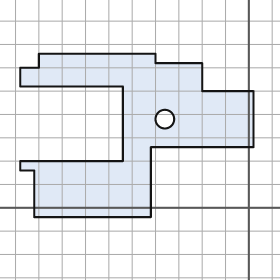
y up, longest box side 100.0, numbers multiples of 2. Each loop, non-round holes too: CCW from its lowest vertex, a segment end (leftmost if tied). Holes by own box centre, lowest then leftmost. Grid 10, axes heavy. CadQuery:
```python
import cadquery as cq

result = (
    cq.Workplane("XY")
    .moveTo(-92.0, -4.0)
    .lineTo(-42.0, -4.0)
    .lineTo(-42.0, 26.0)
    .lineTo(2.0, 26.0)
    .lineTo(2.0, 50.0)
    .lineTo(-20.0, 50.0)
    .lineTo(-20.0, 62.0)
    .lineTo(-40.0, 62.0)
    .lineTo(-40.0, 66.0)
    .lineTo(-90.0, 66.0)
    .lineTo(-90.0, 60.0)
    .lineTo(-98.0, 60.0)
    .lineTo(-98.0, 52.0)
    .lineTo(-54.0, 52.0)
    .lineTo(-54.0, 20.0)
    .lineTo(-98.0, 20.0)
    .lineTo(-98.0, 16.0)
    .lineTo(-92.0, 16.0)
    .close()
    .moveTo(-36.0, 38.0)
    .circle(4.0)
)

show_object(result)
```